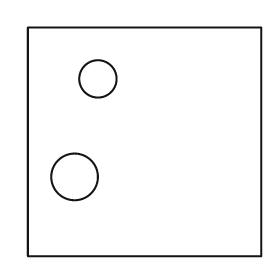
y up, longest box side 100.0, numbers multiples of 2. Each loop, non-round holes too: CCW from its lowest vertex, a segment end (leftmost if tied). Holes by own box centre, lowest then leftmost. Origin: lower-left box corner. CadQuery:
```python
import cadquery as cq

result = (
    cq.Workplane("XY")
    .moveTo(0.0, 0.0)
    .lineTo(100.0, 0.0)
    .lineTo(100.0, 98.0)
    .lineTo(0.0, 98.0)
    .close()
    .moveTo(20.0, 34.0)
    .circle(10.0)
    .moveTo(30.0, 76.0)
    .circle(8.0)
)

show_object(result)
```